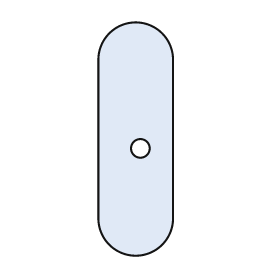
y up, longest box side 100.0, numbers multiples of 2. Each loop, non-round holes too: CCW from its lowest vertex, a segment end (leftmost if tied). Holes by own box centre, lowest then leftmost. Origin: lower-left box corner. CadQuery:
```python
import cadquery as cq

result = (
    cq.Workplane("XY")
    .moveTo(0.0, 16.0)
    .threePointArc((16.0, 0.0), (32.0, 16.0))
    .lineTo(32.0, 84.0)
    .threePointArc((16.0, 100.0), (0.0, 84.0))
    .close()
    .moveTo(18.0, 46.0)
    .circle(4.0)
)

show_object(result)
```